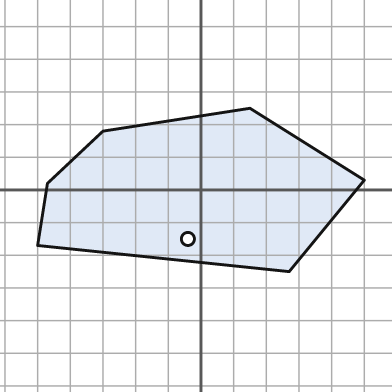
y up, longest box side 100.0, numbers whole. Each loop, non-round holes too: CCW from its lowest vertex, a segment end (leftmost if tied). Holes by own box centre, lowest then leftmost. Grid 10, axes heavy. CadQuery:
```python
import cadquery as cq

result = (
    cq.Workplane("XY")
    .moveTo(27.0, -25.0)
    .lineTo(50.0, 3.0)
    .lineTo(15.0, 25.0)
    .lineTo(-30.0, 18.0)
    .lineTo(-47.0, 2.0)
    .lineTo(-50.0, -17.0)
    .close()
    .moveTo(-4.0, -15.0)
    .circle(2.0)
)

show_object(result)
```